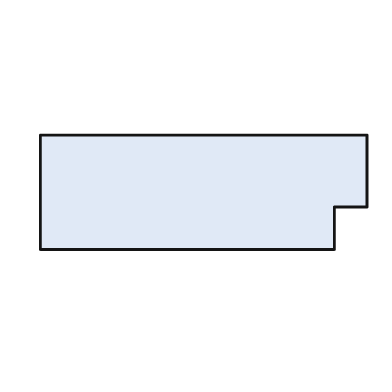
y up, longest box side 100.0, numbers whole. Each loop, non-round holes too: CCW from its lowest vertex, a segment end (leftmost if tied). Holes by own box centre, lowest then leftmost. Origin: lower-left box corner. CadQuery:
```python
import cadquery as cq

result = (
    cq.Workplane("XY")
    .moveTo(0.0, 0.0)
    .lineTo(90.0, 0.0)
    .lineTo(90.0, 13.0)
    .lineTo(100.0, 13.0)
    .lineTo(100.0, 35.0)
    .lineTo(0.0, 35.0)
    .close()
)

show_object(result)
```